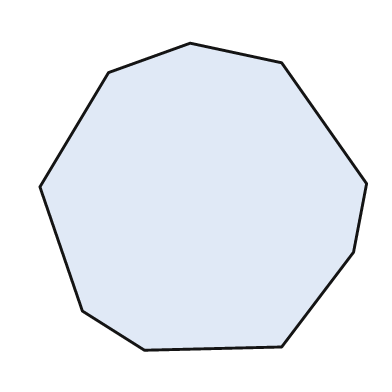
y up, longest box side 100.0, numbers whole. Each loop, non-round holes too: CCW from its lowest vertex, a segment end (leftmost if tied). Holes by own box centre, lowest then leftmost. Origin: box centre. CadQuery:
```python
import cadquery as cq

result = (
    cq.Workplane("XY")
    .moveTo(-18.0, -47.0)
    .lineTo(24.0, -46.0)
    .lineTo(46.0, -17.0)
    .lineTo(50.0, 4.0)
    .lineTo(24.0, 41.0)
    .lineTo(-4.0, 47.0)
    .lineTo(-29.0, 38.0)
    .lineTo(-50.0, 3.0)
    .lineTo(-37.0, -35.0)
    .close()
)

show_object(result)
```